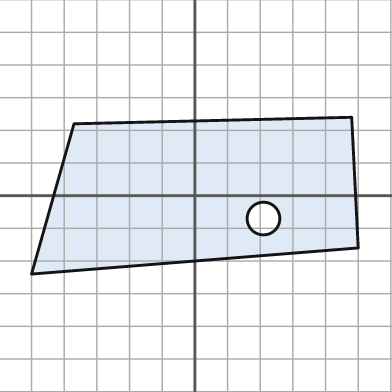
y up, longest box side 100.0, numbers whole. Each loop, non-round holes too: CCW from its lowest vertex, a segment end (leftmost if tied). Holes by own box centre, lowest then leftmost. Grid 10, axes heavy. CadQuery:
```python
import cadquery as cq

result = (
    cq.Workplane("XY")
    .moveTo(-50.0, -24.0)
    .lineTo(50.0, -16.0)
    .lineTo(48.0, 24.0)
    .lineTo(-37.0, 22.0)
    .close()
    .moveTo(21.0, -7.0)
    .circle(5.0)
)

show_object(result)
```